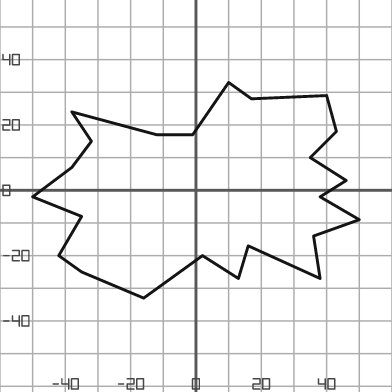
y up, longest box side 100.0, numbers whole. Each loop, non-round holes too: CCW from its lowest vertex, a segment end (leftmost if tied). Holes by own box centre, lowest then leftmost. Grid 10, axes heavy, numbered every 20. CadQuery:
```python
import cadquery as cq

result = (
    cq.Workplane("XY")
    .moveTo(-16.0, -33.0)
    .lineTo(2.0, -20.0)
    .lineTo(13.0, -27.0)
    .lineTo(16.0, -17.0)
    .lineTo(38.0, -27.0)
    .lineTo(36.0, -14.0)
    .lineTo(50.0, -9.0)
    .lineTo(38.0, -2.0)
    .lineTo(46.0, 3.0)
    .lineTo(35.0, 10.0)
    .lineTo(43.0, 18.0)
    .lineTo(40.0, 29.0)
    .lineTo(17.0, 28.0)
    .lineTo(10.0, 33.0)
    .lineTo(-1.0, 17.0)
    .lineTo(-12.0, 17.0)
    .lineTo(-38.0, 24.0)
    .lineTo(-32.0, 15.0)
    .lineTo(-38.0, 7.0)
    .lineTo(-50.0, -2.0)
    .lineTo(-35.0, -8.0)
    .lineTo(-42.0, -20.0)
    .lineTo(-35.0, -25.0)
    .close()
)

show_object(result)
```